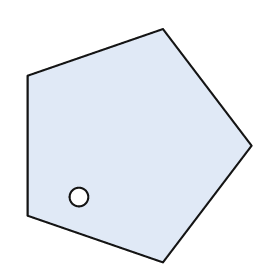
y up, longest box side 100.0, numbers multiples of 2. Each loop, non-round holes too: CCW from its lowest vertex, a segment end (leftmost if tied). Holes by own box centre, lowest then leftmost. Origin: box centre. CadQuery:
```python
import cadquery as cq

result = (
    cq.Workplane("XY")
    .moveTo(10.0, -50.0)
    .lineTo(48.0, 0.0)
    .lineTo(10.0, 50.0)
    .lineTo(-48.0, 30.0)
    .lineTo(-48.0, -30.0)
    .close()
    .moveTo(-26.0, -22.0)
    .circle(4.0)
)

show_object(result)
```